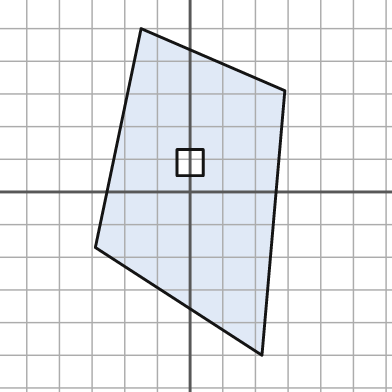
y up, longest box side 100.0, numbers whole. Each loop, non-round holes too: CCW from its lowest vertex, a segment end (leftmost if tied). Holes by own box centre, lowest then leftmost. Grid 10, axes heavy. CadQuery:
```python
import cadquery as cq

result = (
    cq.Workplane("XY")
    .moveTo(22.0, -50.0)
    .lineTo(29.0, 31.0)
    .lineTo(-15.0, 50.0)
    .lineTo(-29.0, -17.0)
    .close()
    .moveTo(-4.0, 5.0)
    .lineTo(4.0, 5.0)
    .lineTo(4.0, 13.0)
    .lineTo(-4.0, 13.0)
    .close()
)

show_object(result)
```